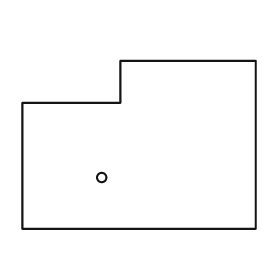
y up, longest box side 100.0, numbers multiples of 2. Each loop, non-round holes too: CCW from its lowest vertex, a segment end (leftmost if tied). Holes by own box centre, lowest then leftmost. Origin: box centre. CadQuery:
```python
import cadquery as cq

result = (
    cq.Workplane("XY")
    .moveTo(-50.0, -36.0)
    .lineTo(50.0, -36.0)
    .lineTo(50.0, 36.0)
    .lineTo(-8.0, 36.0)
    .lineTo(-8.0, 18.0)
    .lineTo(-50.0, 18.0)
    .close()
    .moveTo(-16.0, -14.0)
    .circle(2.0)
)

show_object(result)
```